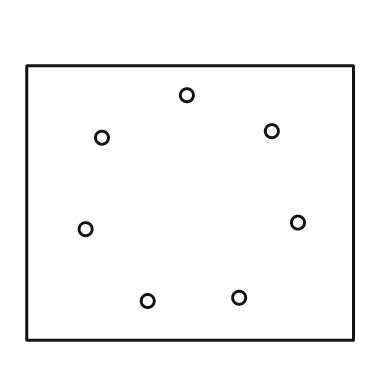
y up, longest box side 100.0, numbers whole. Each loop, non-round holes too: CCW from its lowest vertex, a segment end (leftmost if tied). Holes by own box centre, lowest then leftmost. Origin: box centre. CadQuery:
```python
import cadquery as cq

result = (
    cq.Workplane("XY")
    .moveTo(-50.0, -42.0)
    .lineTo(50.0, -42.0)
    .lineTo(50.0, 42.0)
    .lineTo(-50.0, 42.0)
    .close()
    .moveTo(-13.0, -30.0)
    .circle(2.0)
    .moveTo(15.0, -29.0)
    .circle(2.0)
    .moveTo(-32.0, -8.0)
    .circle(2.0)
    .moveTo(33.0, -6.0)
    .circle(2.0)
    .moveTo(-27.0, 20.0)
    .circle(2.0)
    .moveTo(25.0, 22.0)
    .circle(2.0)
    .moveTo(-1.0, 33.0)
    .circle(2.0)
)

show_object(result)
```